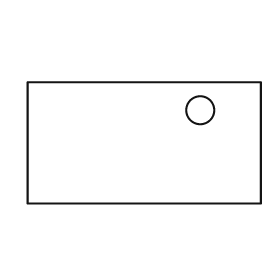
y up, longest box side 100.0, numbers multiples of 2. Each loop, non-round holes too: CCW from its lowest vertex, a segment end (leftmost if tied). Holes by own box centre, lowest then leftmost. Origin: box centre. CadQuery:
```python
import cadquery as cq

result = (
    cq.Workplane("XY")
    .moveTo(-50.0, -26.0)
    .lineTo(50.0, -26.0)
    .lineTo(50.0, 26.0)
    .lineTo(-50.0, 26.0)
    .close()
    .moveTo(24.0, 14.0)
    .circle(6.0)
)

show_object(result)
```